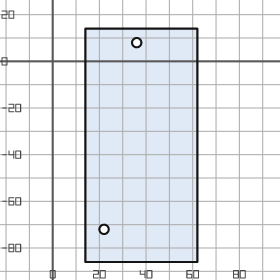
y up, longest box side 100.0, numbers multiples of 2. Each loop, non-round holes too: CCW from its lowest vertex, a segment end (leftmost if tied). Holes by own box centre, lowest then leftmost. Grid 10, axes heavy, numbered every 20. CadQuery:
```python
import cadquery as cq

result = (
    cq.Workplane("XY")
    .moveTo(14.0, -86.0)
    .lineTo(62.0, -86.0)
    .lineTo(62.0, 14.0)
    .lineTo(14.0, 14.0)
    .close()
    .moveTo(22.0, -72.0)
    .circle(2.0)
    .moveTo(36.0, 8.0)
    .circle(2.0)
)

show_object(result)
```